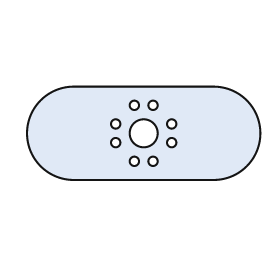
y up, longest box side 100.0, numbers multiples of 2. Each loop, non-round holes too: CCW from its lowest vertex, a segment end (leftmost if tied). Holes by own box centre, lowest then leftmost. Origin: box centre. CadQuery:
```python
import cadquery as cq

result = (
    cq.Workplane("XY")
    .moveTo(-30.0, -20.0)
    .lineTo(30.0, -20.0)
    .threePointArc((50.0, 0.0), (30.0, 20.0))
    .lineTo(-30.0, 20.0)
    .threePointArc((-50.0, 0.0), (-30.0, -20.0))
    .close()
    .moveTo(-4.0, -12.0)
    .circle(2.0)
    .moveTo(4.0, -12.0)
    .circle(2.0)
    .moveTo(-12.0, -4.0)
    .circle(2.0)
    .moveTo(12.0, -4.0)
    .circle(2.0)
    .moveTo(0.0, 0.0)
    .circle(6.0)
    .moveTo(-12.0, 4.0)
    .circle(2.0)
    .moveTo(12.0, 4.0)
    .circle(2.0)
    .moveTo(-4.0, 12.0)
    .circle(2.0)
    .moveTo(4.0, 12.0)
    .circle(2.0)
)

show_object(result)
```